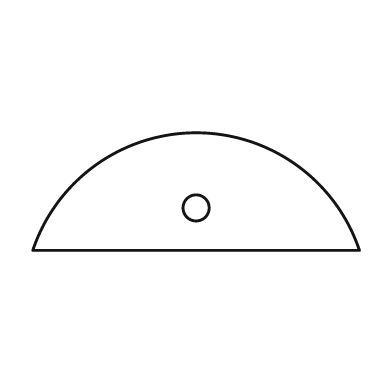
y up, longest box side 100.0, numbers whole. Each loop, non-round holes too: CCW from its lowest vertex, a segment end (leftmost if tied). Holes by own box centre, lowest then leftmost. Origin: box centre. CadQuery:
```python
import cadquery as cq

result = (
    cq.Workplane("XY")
    .moveTo(-50.0, -18.0)
    .lineTo(50.0, -18.0)
    .threePointArc((0.0, 18.0), (-50.0, -18.0))
    .close()
    .moveTo(0.0, -5.0)
    .circle(4.0)
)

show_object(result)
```